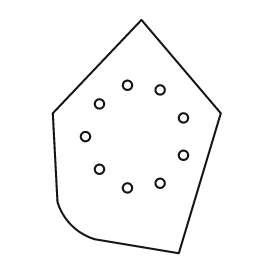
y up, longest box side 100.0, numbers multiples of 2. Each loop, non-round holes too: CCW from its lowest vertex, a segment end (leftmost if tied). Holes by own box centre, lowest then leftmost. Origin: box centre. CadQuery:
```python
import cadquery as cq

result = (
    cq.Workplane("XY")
    .moveTo(18.0, -50.0)
    .lineTo(36.0, 10.0)
    .lineTo(2.0, 50.0)
    .lineTo(-36.0, 10.0)
    .lineTo(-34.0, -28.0)
    .threePointArc((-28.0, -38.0), (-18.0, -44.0))
    .close()
    .moveTo(-4.0, -22.0)
    .circle(2.0)
    .moveTo(10.0, -20.0)
    .circle(2.0)
    .moveTo(-16.0, -14.0)
    .circle(2.0)
    .moveTo(20.0, -8.0)
    .circle(2.0)
    .moveTo(-22.0, 0.0)
    .circle(2.0)
    .moveTo(20.0, 8.0)
    .circle(2.0)
    .moveTo(-16.0, 14.0)
    .circle(2.0)
    .moveTo(10.0, 20.0)
    .circle(2.0)
    .moveTo(-4.0, 22.0)
    .circle(2.0)
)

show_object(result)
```